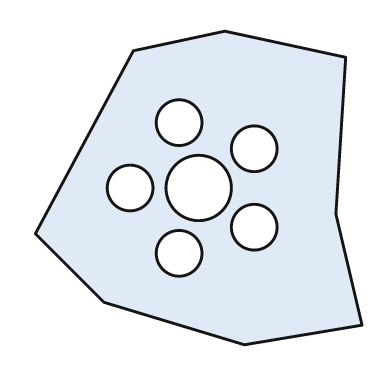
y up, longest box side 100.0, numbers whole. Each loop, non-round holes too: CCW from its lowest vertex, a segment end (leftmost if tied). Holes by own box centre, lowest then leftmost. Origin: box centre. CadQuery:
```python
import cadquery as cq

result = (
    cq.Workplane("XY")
    .moveTo(14.0, -48.0)
    .lineTo(50.0, -42.0)
    .lineTo(42.0, -8.0)
    .lineTo(45.0, 40.0)
    .lineTo(8.0, 48.0)
    .lineTo(-20.0, 42.0)
    .lineTo(-50.0, -14.0)
    .lineTo(-29.0, -35.0)
    .close()
    .moveTo(-6.0, -20.0)
    .circle(7.0)
    .moveTo(17.0, -12.0)
    .circle(7.0)
    .moveTo(-21.0, 0.0)
    .circle(7.0)
    .moveTo(0.0, 0.0)
    .circle(10.0)
    .moveTo(17.0, 12.0)
    .circle(7.0)
    .moveTo(-6.0, 20.0)
    .circle(7.0)
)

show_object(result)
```